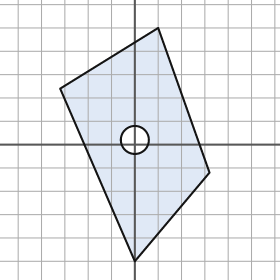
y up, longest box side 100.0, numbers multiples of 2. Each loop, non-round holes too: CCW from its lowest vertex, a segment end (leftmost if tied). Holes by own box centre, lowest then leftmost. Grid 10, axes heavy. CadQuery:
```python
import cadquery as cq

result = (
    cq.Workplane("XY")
    .moveTo(0.0, -50.0)
    .lineTo(32.0, -12.0)
    .lineTo(10.0, 50.0)
    .lineTo(-32.0, 24.0)
    .close()
    .moveTo(0.0, 2.0)
    .circle(6.0)
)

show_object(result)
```